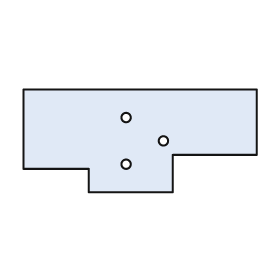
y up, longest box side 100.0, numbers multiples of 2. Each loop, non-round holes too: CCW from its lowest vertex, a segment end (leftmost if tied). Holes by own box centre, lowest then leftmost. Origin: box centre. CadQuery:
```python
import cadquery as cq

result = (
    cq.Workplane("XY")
    .moveTo(-22.0, -22.0)
    .lineTo(14.0, -22.0)
    .lineTo(14.0, -6.0)
    .lineTo(50.0, -6.0)
    .lineTo(50.0, 22.0)
    .lineTo(-50.0, 22.0)
    .lineTo(-50.0, -12.0)
    .lineTo(-22.0, -12.0)
    .close()
    .moveTo(-6.0, -10.0)
    .circle(2.0)
    .moveTo(10.0, 0.0)
    .circle(2.0)
    .moveTo(-6.0, 10.0)
    .circle(2.0)
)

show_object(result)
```